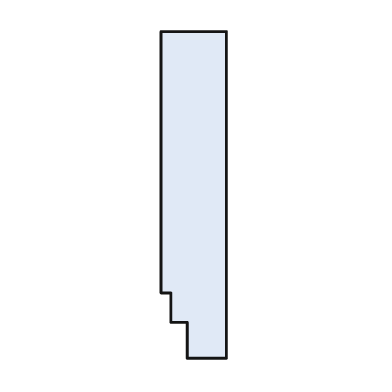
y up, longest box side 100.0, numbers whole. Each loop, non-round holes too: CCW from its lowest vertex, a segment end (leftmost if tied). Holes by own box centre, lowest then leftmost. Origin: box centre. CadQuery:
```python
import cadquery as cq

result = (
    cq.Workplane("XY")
    .moveTo(-2.0, -50.0)
    .lineTo(10.0, -50.0)
    .lineTo(10.0, 50.0)
    .lineTo(-10.0, 50.0)
    .lineTo(-10.0, -30.0)
    .lineTo(-7.0, -30.0)
    .lineTo(-7.0, -39.0)
    .lineTo(-2.0, -39.0)
    .close()
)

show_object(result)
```